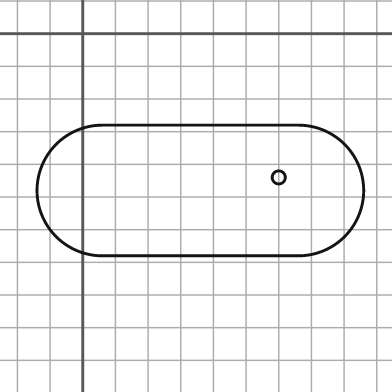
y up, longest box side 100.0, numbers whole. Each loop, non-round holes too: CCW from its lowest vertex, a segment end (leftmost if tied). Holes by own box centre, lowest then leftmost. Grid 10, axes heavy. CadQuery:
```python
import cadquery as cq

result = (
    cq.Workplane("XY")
    .moveTo(6.0, -68.0)
    .lineTo(66.0, -68.0)
    .threePointArc((86.0, -48.0), (66.0, -28.0))
    .lineTo(6.0, -28.0)
    .threePointArc((-14.0, -48.0), (6.0, -68.0))
    .close()
    .moveTo(60.0, -44.0)
    .circle(2.0)
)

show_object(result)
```